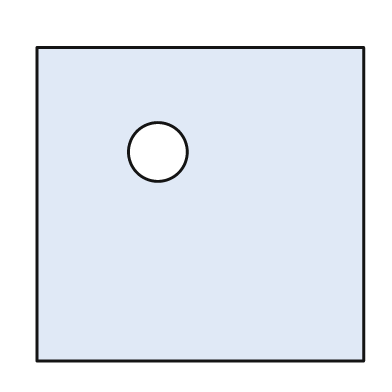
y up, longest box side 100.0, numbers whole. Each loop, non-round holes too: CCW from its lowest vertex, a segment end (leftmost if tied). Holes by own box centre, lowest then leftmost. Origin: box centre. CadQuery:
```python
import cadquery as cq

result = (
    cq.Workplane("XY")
    .moveTo(-50.0, -48.0)
    .lineTo(50.0, -48.0)
    .lineTo(50.0, 48.0)
    .lineTo(-50.0, 48.0)
    .close()
    .moveTo(-13.0, 16.0)
    .circle(9.0)
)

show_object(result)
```